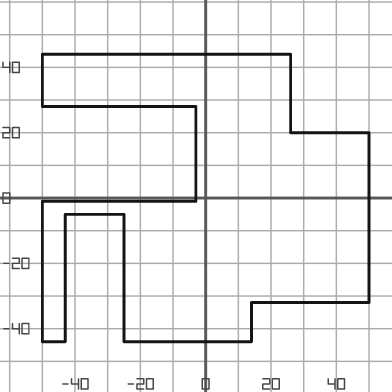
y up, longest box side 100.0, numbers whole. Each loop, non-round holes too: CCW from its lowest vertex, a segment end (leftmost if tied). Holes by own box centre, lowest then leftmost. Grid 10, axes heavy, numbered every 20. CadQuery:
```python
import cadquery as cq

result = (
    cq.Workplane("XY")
    .moveTo(-50.0, -44.0)
    .lineTo(-43.0, -44.0)
    .lineTo(-43.0, -5.0)
    .lineTo(-25.0, -5.0)
    .lineTo(-25.0, -44.0)
    .lineTo(14.0, -44.0)
    .lineTo(14.0, -32.0)
    .lineTo(50.0, -32.0)
    .lineTo(50.0, 20.0)
    .lineTo(26.0, 20.0)
    .lineTo(26.0, 44.0)
    .lineTo(-50.0, 44.0)
    .lineTo(-50.0, 28.0)
    .lineTo(-3.0, 28.0)
    .lineTo(-3.0, -1.0)
    .lineTo(-50.0, -1.0)
    .close()
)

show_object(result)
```